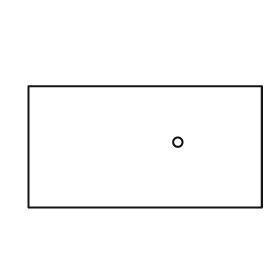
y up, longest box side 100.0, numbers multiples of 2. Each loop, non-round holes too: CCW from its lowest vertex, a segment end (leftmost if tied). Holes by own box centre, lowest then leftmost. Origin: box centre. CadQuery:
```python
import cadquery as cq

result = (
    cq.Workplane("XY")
    .moveTo(-50.0, -26.0)
    .lineTo(50.0, -26.0)
    .lineTo(50.0, 26.0)
    .lineTo(-50.0, 26.0)
    .close()
    .moveTo(14.0, 2.0)
    .circle(2.0)
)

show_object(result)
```